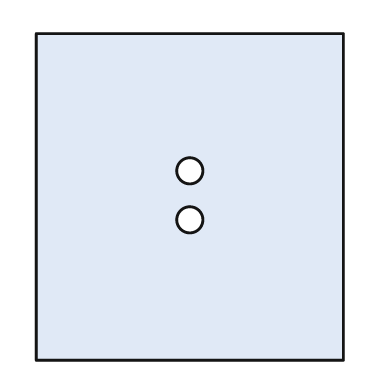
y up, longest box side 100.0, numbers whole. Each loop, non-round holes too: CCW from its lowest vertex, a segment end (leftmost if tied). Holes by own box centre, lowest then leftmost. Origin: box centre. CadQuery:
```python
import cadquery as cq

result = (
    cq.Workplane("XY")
    .moveTo(-47.0, -50.0)
    .lineTo(47.0, -50.0)
    .lineTo(47.0, 50.0)
    .lineTo(-47.0, 50.0)
    .close()
    .moveTo(0.0, -7.0)
    .circle(4.0)
    .moveTo(0.0, 8.0)
    .circle(4.0)
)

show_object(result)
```